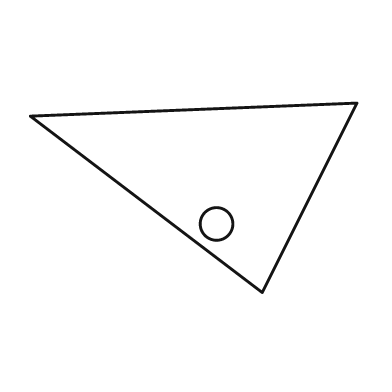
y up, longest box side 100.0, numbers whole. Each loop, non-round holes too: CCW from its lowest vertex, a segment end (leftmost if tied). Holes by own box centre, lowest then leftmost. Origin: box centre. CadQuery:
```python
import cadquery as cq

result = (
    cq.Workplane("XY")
    .moveTo(21.0, -29.0)
    .lineTo(50.0, 29.0)
    .lineTo(-50.0, 25.0)
    .close()
    .moveTo(7.0, -8.0)
    .circle(5.0)
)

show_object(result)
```